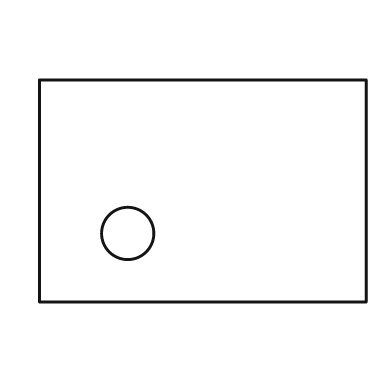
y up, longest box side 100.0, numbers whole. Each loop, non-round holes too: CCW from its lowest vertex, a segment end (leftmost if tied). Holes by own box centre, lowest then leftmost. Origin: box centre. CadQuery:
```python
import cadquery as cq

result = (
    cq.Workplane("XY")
    .moveTo(-50.0, -34.0)
    .lineTo(50.0, -34.0)
    .lineTo(50.0, 34.0)
    .lineTo(-50.0, 34.0)
    .close()
    .moveTo(-23.0, -13.0)
    .circle(8.0)
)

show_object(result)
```